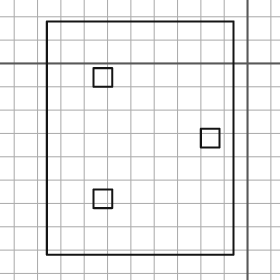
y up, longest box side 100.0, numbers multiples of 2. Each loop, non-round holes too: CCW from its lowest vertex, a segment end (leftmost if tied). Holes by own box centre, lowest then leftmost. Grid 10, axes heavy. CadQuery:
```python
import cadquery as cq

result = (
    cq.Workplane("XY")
    .moveTo(-86.0, -82.0)
    .lineTo(-6.0, -82.0)
    .lineTo(-6.0, 18.0)
    .lineTo(-86.0, 18.0)
    .close()
    .moveTo(-66.0, -62.0)
    .lineTo(-58.0, -62.0)
    .lineTo(-58.0, -54.0)
    .lineTo(-66.0, -54.0)
    .close()
    .moveTo(-20.0, -36.0)
    .lineTo(-12.0, -36.0)
    .lineTo(-12.0, -28.0)
    .lineTo(-20.0, -28.0)
    .close()
    .moveTo(-66.0, -10.0)
    .lineTo(-58.0, -10.0)
    .lineTo(-58.0, -2.0)
    .lineTo(-66.0, -2.0)
    .close()
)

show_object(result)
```